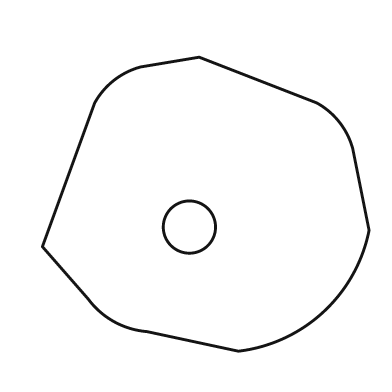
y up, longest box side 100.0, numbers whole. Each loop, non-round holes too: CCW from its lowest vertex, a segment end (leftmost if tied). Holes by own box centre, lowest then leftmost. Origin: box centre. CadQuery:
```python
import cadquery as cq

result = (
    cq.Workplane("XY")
    .moveTo(10.0, -45.0)
    .threePointArc((36.0, -33.0), (50.0, -8.0))
    .lineTo(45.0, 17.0)
    .threePointArc((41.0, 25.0), (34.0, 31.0))
    .lineTo(-2.0, 45.0)
    .lineTo(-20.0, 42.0)
    .threePointArc((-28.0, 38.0), (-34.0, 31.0))
    .lineTo(-50.0, -13.0)
    .lineTo(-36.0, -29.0)
    .threePointArc((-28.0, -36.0), (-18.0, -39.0))
    .close()
    .moveTo(-5.0, -7.0)
    .circle(8.0)
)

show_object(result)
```